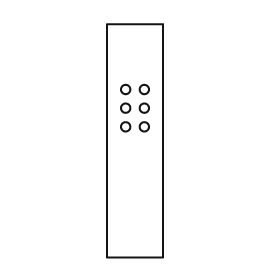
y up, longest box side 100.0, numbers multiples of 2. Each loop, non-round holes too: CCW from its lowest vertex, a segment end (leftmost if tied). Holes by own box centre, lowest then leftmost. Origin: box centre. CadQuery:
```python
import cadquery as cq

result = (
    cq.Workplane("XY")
    .moveTo(-12.0, -50.0)
    .lineTo(12.0, -50.0)
    .lineTo(12.0, 50.0)
    .lineTo(-12.0, 50.0)
    .close()
    .moveTo(-4.0, 6.0)
    .circle(2.0)
    .moveTo(4.0, 6.0)
    .circle(2.0)
    .moveTo(-4.0, 14.0)
    .circle(2.0)
    .moveTo(4.0, 14.0)
    .circle(2.0)
    .moveTo(-4.0, 22.0)
    .circle(2.0)
    .moveTo(4.0, 22.0)
    .circle(2.0)
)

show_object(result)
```